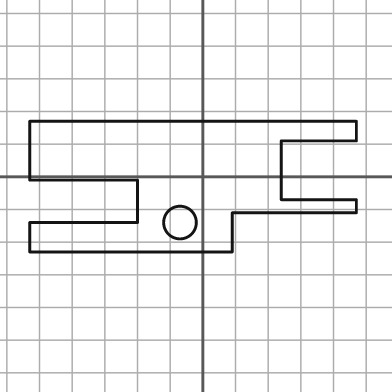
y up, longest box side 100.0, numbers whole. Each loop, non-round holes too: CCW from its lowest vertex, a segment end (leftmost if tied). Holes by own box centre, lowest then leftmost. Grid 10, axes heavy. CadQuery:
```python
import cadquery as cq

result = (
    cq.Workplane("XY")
    .moveTo(-53.0, -23.0)
    .lineTo(9.0, -23.0)
    .lineTo(9.0, -11.0)
    .lineTo(47.0, -11.0)
    .lineTo(47.0, -7.0)
    .lineTo(24.0, -7.0)
    .lineTo(24.0, 11.0)
    .lineTo(47.0, 11.0)
    .lineTo(47.0, 17.0)
    .lineTo(-53.0, 17.0)
    .lineTo(-53.0, -1.0)
    .lineTo(-20.0, -1.0)
    .lineTo(-20.0, -14.0)
    .lineTo(-53.0, -14.0)
    .close()
    .moveTo(-7.0, -14.0)
    .circle(5.0)
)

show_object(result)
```